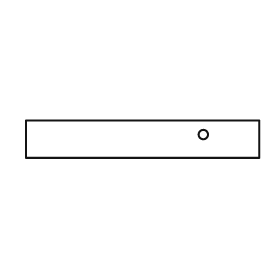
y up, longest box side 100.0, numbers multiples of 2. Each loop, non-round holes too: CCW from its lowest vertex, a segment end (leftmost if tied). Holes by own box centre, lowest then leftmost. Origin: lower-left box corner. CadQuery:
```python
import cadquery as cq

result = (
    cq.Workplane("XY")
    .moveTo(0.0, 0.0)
    .lineTo(100.0, 0.0)
    .lineTo(100.0, 16.0)
    .lineTo(0.0, 16.0)
    .close()
    .moveTo(76.0, 10.0)
    .circle(2.0)
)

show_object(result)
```